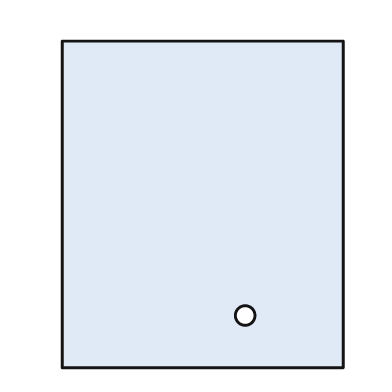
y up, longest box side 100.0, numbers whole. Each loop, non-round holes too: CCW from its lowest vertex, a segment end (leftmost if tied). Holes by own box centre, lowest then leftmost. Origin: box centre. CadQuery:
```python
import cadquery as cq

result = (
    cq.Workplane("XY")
    .moveTo(-43.0, -50.0)
    .lineTo(43.0, -50.0)
    .lineTo(43.0, 50.0)
    .lineTo(-43.0, 50.0)
    .close()
    .moveTo(13.0, -34.0)
    .circle(3.0)
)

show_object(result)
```